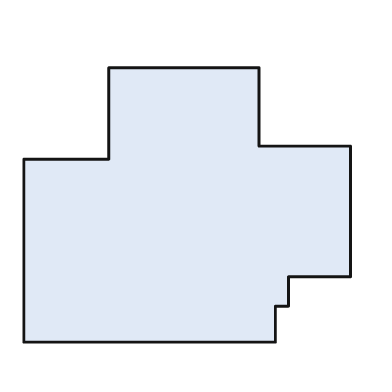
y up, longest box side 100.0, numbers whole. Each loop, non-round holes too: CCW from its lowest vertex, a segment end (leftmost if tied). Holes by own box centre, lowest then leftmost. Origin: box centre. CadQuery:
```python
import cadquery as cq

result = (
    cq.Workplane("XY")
    .moveTo(-50.0, -42.0)
    .lineTo(27.0, -42.0)
    .lineTo(27.0, -31.0)
    .lineTo(31.0, -31.0)
    .lineTo(31.0, -22.0)
    .lineTo(50.0, -22.0)
    .lineTo(50.0, 18.0)
    .lineTo(22.0, 18.0)
    .lineTo(22.0, 42.0)
    .lineTo(-24.0, 42.0)
    .lineTo(-24.0, 14.0)
    .lineTo(-50.0, 14.0)
    .close()
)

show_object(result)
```